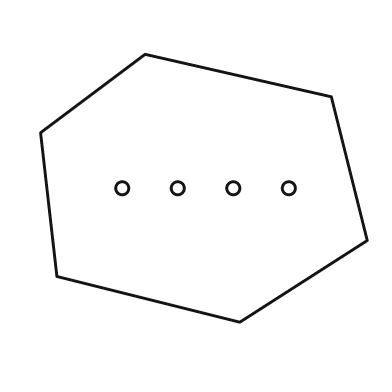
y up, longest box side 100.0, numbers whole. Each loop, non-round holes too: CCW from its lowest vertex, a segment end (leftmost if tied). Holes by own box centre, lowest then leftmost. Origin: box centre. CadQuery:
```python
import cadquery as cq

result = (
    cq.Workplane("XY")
    .moveTo(11.0, -41.0)
    .lineTo(50.0, -16.0)
    .lineTo(39.0, 28.0)
    .lineTo(-18.0, 41.0)
    .lineTo(-50.0, 17.0)
    .lineTo(-45.0, -27.0)
    .close()
    .moveTo(-25.0, 0.0)
    .circle(2.0)
    .moveTo(-8.0, 0.0)
    .circle(2.0)
    .moveTo(9.0, 0.0)
    .circle(2.0)
    .moveTo(26.0, 0.0)
    .circle(2.0)
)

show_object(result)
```